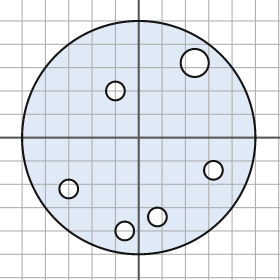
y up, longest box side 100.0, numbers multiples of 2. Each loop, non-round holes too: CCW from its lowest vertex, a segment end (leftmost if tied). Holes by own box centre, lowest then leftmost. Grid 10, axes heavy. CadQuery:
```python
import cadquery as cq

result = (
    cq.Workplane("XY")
    .moveTo(0.0, 0.0)
    .circle(50.0)
    .moveTo(-6.0, -40.0)
    .circle(4.0)
    .moveTo(8.0, -34.0)
    .circle(4.0)
    .moveTo(-30.0, -22.0)
    .circle(4.0)
    .moveTo(32.0, -14.0)
    .circle(4.0)
    .moveTo(-10.0, 20.0)
    .circle(4.0)
    .moveTo(24.0, 32.0)
    .circle(6.0)
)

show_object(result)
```